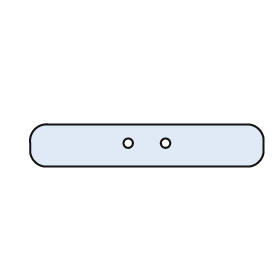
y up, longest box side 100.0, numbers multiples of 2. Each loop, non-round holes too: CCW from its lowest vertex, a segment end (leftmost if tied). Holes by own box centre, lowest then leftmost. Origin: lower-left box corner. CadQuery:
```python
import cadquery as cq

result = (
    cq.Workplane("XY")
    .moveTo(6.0, 0.0)
    .lineTo(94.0, 0.0)
    .threePointArc((98.0, 2.0), (100.0, 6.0))
    .lineTo(100.0, 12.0)
    .threePointArc((98.0, 16.0), (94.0, 18.0))
    .lineTo(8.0, 18.0)
    .threePointArc((2.0, 16.0), (0.0, 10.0))
    .lineTo(0.0, 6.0)
    .threePointArc((2.0, 2.0), (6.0, 0.0))
    .close()
    .moveTo(42.0, 10.0)
    .circle(2.0)
    .moveTo(58.0, 10.0)
    .circle(2.0)
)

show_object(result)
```